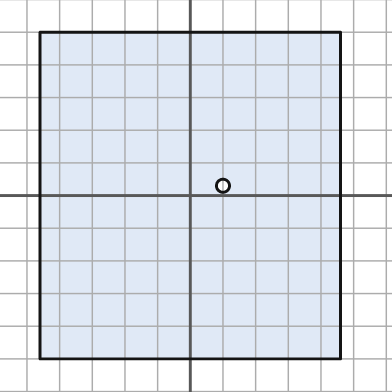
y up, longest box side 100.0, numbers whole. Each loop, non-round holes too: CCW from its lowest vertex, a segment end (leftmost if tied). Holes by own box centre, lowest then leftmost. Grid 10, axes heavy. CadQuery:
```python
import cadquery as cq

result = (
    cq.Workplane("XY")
    .moveTo(-46.0, -50.0)
    .lineTo(46.0, -50.0)
    .lineTo(46.0, 50.0)
    .lineTo(-46.0, 50.0)
    .close()
    .moveTo(10.0, 3.0)
    .circle(2.0)
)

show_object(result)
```